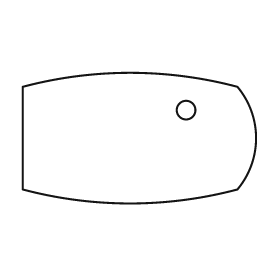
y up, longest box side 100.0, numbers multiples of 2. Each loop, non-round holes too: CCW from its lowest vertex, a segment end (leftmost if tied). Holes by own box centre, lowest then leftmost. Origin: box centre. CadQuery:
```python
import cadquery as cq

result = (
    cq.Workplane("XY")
    .moveTo(-50.0, -22.0)
    .threePointArc((-4.0, -28.0), (42.0, -22.0))
    .threePointArc((50.0, 0.0), (42.0, 22.0))
    .threePointArc((-4.0, 28.0), (-50.0, 22.0))
    .close()
    .moveTo(20.0, 12.0)
    .circle(4.0)
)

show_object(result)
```